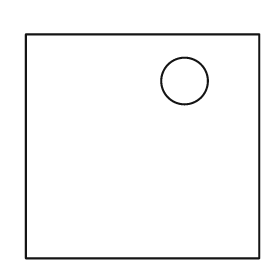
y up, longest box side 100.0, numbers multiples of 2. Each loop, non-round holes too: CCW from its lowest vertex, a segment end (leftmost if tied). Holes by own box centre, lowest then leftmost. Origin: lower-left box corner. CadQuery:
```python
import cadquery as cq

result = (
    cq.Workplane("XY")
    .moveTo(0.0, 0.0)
    .lineTo(100.0, 0.0)
    .lineTo(100.0, 96.0)
    .lineTo(0.0, 96.0)
    .close()
    .moveTo(68.0, 76.0)
    .circle(10.0)
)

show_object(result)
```